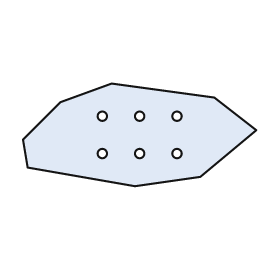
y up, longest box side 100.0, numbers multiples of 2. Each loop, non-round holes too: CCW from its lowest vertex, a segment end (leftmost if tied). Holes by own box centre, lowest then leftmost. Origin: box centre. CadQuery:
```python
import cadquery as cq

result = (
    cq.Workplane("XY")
    .moveTo(-2.0, -22.0)
    .lineTo(26.0, -18.0)
    .lineTo(50.0, 2.0)
    .lineTo(32.0, 16.0)
    .lineTo(-12.0, 22.0)
    .lineTo(-34.0, 14.0)
    .lineTo(-50.0, -2.0)
    .lineTo(-48.0, -14.0)
    .close()
    .moveTo(-16.0, -8.0)
    .circle(2.0)
    .moveTo(0.0, -8.0)
    .circle(2.0)
    .moveTo(16.0, -8.0)
    .circle(2.0)
    .moveTo(-16.0, 8.0)
    .circle(2.0)
    .moveTo(0.0, 8.0)
    .circle(2.0)
    .moveTo(16.0, 8.0)
    .circle(2.0)
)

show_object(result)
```